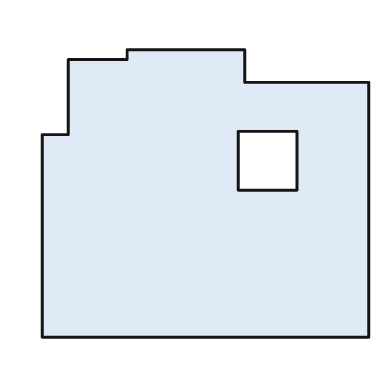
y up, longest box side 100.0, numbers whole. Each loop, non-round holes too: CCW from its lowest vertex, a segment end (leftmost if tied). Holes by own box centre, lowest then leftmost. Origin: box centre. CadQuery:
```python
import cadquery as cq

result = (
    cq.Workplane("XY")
    .moveTo(-50.0, -44.0)
    .lineTo(50.0, -44.0)
    .lineTo(50.0, 34.0)
    .lineTo(12.0, 34.0)
    .lineTo(12.0, 44.0)
    .lineTo(-24.0, 44.0)
    .lineTo(-24.0, 41.0)
    .lineTo(-42.0, 41.0)
    .lineTo(-42.0, 18.0)
    .lineTo(-50.0, 18.0)
    .close()
    .moveTo(10.0, 1.0)
    .lineTo(28.0, 1.0)
    .lineTo(28.0, 19.0)
    .lineTo(10.0, 19.0)
    .close()
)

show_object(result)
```